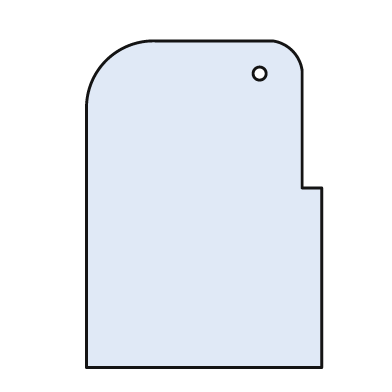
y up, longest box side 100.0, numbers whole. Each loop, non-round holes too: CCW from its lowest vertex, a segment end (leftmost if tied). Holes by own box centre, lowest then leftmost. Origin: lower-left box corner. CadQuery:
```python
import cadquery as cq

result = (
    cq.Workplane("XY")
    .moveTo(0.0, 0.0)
    .lineTo(72.0, 0.0)
    .lineTo(72.0, 55.0)
    .lineTo(66.0, 55.0)
    .lineTo(66.0, 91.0)
    .threePointArc((63.0, 97.0), (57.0, 100.0))
    .lineTo(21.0, 100.0)
    .threePointArc((6.0, 94.0), (0.0, 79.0))
    .close()
    .moveTo(53.0, 90.0)
    .circle(2.0)
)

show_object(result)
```